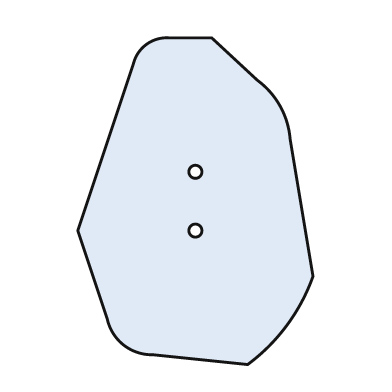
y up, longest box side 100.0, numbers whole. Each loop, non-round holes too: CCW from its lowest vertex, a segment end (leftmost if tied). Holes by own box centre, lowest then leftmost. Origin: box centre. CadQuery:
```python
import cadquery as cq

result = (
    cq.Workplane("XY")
    .moveTo(16.0, -50.0)
    .threePointArc((28.0, -38.0), (36.0, -23.0))
    .lineTo(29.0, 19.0)
    .threePointArc((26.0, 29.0), (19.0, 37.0))
    .lineTo(5.0, 50.0)
    .lineTo(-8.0, 50.0)
    .threePointArc((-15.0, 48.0), (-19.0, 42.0))
    .lineTo(-36.0, -9.0)
    .lineTo(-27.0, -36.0)
    .threePointArc((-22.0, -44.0), (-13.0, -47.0))
    .close()
    .moveTo(0.0, -9.0)
    .circle(2.0)
    .moveTo(0.0, 9.0)
    .circle(2.0)
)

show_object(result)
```